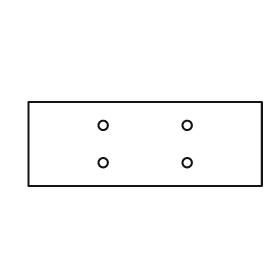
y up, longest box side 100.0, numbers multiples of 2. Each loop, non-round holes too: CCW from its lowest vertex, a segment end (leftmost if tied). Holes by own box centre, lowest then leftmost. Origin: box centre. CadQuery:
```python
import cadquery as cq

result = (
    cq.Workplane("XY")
    .moveTo(-50.0, -18.0)
    .lineTo(50.0, -18.0)
    .lineTo(50.0, 18.0)
    .lineTo(-50.0, 18.0)
    .close()
    .moveTo(-18.0, -8.0)
    .circle(2.0)
    .moveTo(18.0, -8.0)
    .circle(2.0)
    .moveTo(-18.0, 8.0)
    .circle(2.0)
    .moveTo(18.0, 8.0)
    .circle(2.0)
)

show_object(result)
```